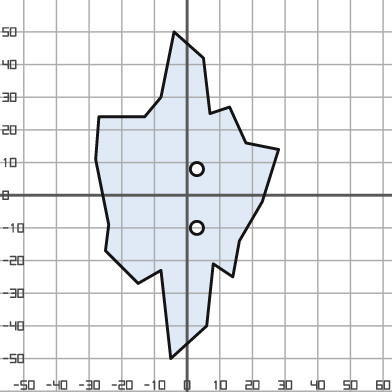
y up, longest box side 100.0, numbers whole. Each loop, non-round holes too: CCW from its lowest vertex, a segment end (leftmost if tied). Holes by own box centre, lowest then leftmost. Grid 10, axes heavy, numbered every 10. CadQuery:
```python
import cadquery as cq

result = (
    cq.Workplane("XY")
    .moveTo(-5.0, -50.0)
    .lineTo(6.0, -40.0)
    .lineTo(8.0, -21.0)
    .lineTo(14.0, -25.0)
    .lineTo(16.0, -14.0)
    .lineTo(23.0, -2.0)
    .lineTo(28.0, 14.0)
    .lineTo(18.0, 16.0)
    .lineTo(13.0, 27.0)
    .lineTo(7.0, 25.0)
    .lineTo(5.0, 42.0)
    .lineTo(-4.0, 50.0)
    .lineTo(-8.0, 30.0)
    .lineTo(-13.0, 24.0)
    .lineTo(-27.0, 24.0)
    .lineTo(-28.0, 11.0)
    .lineTo(-24.0, -9.0)
    .lineTo(-25.0, -17.0)
    .lineTo(-15.0, -27.0)
    .lineTo(-8.0, -23.0)
    .close()
    .moveTo(3.0, -10.0)
    .circle(2.0)
    .moveTo(3.0, 8.0)
    .circle(2.0)
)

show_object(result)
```